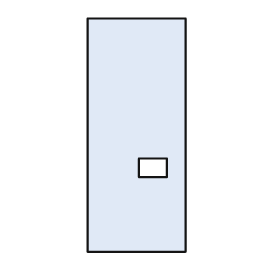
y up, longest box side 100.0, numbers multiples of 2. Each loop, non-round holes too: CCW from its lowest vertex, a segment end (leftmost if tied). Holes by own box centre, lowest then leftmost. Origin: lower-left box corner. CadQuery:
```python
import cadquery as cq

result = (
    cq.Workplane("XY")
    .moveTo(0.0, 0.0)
    .lineTo(42.0, 0.0)
    .lineTo(42.0, 100.0)
    .lineTo(0.0, 100.0)
    .close()
    .moveTo(22.0, 32.0)
    .lineTo(34.0, 32.0)
    .lineTo(34.0, 40.0)
    .lineTo(22.0, 40.0)
    .close()
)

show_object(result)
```